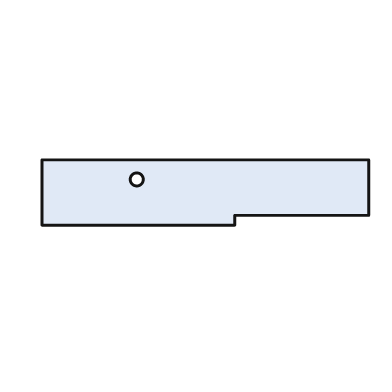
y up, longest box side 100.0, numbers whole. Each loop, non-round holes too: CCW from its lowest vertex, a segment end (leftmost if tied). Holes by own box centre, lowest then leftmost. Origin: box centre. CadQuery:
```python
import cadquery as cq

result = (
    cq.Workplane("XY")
    .moveTo(-50.0, -10.0)
    .lineTo(9.0, -10.0)
    .lineTo(9.0, -7.0)
    .lineTo(50.0, -7.0)
    .lineTo(50.0, 10.0)
    .lineTo(-50.0, 10.0)
    .close()
    .moveTo(-21.0, 4.0)
    .circle(2.0)
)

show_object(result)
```